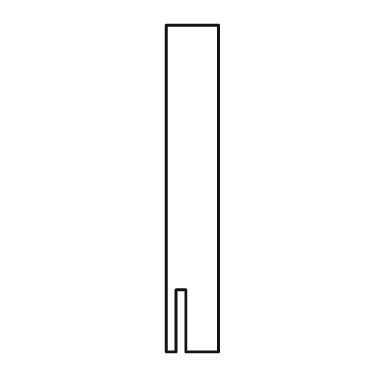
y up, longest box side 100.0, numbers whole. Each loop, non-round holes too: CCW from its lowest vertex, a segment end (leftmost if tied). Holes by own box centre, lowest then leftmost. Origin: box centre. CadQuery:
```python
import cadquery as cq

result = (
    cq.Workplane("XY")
    .moveTo(-8.0, -50.0)
    .lineTo(-5.0, -50.0)
    .lineTo(-5.0, -31.0)
    .lineTo(-2.0, -31.0)
    .lineTo(-2.0, -50.0)
    .lineTo(8.0, -50.0)
    .lineTo(8.0, 50.0)
    .lineTo(-8.0, 50.0)
    .close()
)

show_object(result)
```